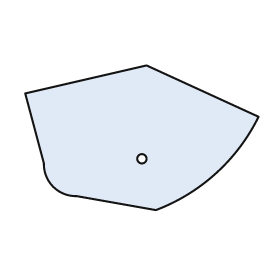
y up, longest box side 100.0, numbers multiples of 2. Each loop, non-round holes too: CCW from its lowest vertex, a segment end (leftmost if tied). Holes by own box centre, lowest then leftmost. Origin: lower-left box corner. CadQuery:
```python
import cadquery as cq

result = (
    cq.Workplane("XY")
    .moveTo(56.0, 0.0)
    .threePointArc((82.0, 16.0), (100.0, 40.0))
    .lineTo(52.0, 62.0)
    .lineTo(0.0, 50.0)
    .lineTo(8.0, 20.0)
    .threePointArc((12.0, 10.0), (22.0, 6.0))
    .close()
    .moveTo(50.0, 22.0)
    .circle(2.0)
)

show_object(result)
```